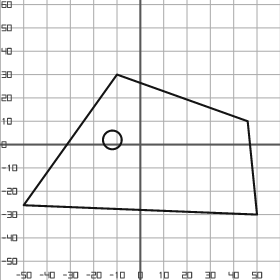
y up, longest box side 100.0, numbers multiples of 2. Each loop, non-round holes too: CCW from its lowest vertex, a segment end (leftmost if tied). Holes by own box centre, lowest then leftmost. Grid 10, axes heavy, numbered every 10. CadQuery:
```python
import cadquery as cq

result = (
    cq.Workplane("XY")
    .moveTo(50.0, -30.0)
    .lineTo(46.0, 10.0)
    .lineTo(-10.0, 30.0)
    .lineTo(-50.0, -26.0)
    .close()
    .moveTo(-12.0, 2.0)
    .circle(4.0)
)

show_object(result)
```